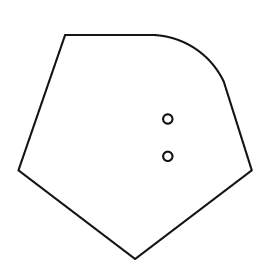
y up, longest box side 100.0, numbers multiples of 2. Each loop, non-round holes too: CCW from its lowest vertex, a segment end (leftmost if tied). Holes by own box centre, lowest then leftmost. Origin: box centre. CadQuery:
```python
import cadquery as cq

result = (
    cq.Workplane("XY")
    .moveTo(0.0, -48.0)
    .lineTo(50.0, -10.0)
    .lineTo(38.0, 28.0)
    .threePointArc((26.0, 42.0), (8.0, 48.0))
    .lineTo(-30.0, 48.0)
    .lineTo(-50.0, -10.0)
    .close()
    .moveTo(14.0, -4.0)
    .circle(2.0)
    .moveTo(14.0, 12.0)
    .circle(2.0)
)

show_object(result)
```